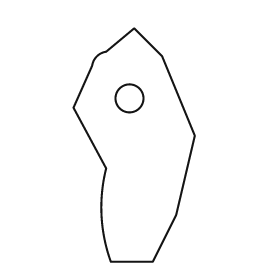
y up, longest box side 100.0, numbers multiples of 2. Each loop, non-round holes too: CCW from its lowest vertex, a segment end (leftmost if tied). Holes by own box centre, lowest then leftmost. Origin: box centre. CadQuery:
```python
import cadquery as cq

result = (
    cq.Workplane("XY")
    .moveTo(-10.0, -50.0)
    .lineTo(8.0, -50.0)
    .lineTo(18.0, -30.0)
    .lineTo(26.0, 4.0)
    .lineTo(12.0, 38.0)
    .lineTo(0.0, 50.0)
    .lineTo(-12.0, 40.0)
    .threePointArc((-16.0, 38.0), (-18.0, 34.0))
    .lineTo(-26.0, 16.0)
    .lineTo(-12.0, -10.0)
    .threePointArc((-14.0, -30.0), (-10.0, -50.0))
    .close()
    .moveTo(-2.0, 20.0)
    .circle(6.0)
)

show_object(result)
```